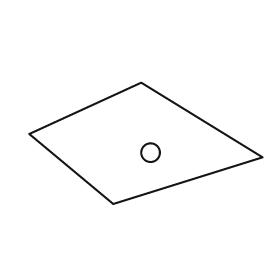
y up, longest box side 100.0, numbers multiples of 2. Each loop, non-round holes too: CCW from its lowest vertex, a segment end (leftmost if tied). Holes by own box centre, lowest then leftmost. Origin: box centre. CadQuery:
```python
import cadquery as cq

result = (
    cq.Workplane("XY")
    .moveTo(-14.0, -26.0)
    .lineTo(50.0, -6.0)
    .lineTo(-2.0, 26.0)
    .lineTo(-50.0, 4.0)
    .close()
    .moveTo(2.0, -4.0)
    .circle(4.0)
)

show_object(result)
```